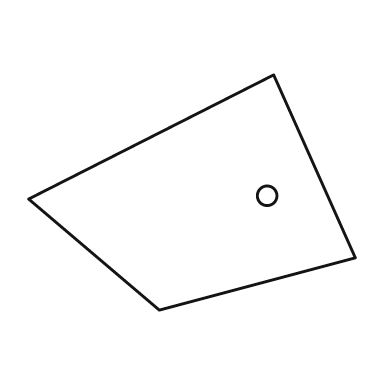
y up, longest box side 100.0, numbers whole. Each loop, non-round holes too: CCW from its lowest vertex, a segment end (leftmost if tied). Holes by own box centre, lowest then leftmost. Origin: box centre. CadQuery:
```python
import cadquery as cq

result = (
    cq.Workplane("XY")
    .moveTo(-10.0, -36.0)
    .lineTo(50.0, -20.0)
    .lineTo(25.0, 36.0)
    .lineTo(-50.0, -2.0)
    .close()
    .moveTo(23.0, -1.0)
    .circle(3.0)
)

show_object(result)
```